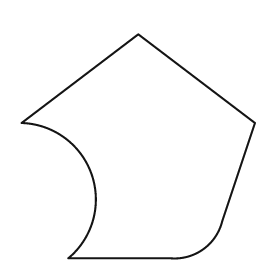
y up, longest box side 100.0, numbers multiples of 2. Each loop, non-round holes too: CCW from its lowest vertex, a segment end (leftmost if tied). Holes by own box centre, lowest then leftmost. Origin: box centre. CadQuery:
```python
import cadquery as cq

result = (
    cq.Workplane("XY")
    .moveTo(-30.0, -48.0)
    .lineTo(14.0, -48.0)
    .threePointArc((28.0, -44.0), (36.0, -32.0))
    .lineTo(50.0, 10.0)
    .lineTo(0.0, 48.0)
    .lineTo(-50.0, 10.0)
    .threePointArc((-20.0, -12.0), (-30.0, -48.0))
    .close()
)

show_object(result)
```